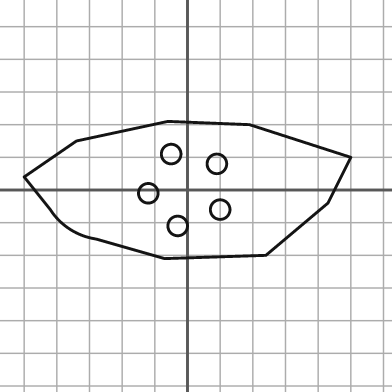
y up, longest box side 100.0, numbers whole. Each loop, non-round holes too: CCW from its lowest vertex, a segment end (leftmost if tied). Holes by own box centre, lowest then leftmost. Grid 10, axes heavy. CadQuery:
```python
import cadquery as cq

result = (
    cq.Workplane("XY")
    .moveTo(-7.0, -21.0)
    .lineTo(24.0, -20.0)
    .lineTo(43.0, -4.0)
    .lineTo(50.0, 10.0)
    .lineTo(19.0, 20.0)
    .lineTo(-6.0, 21.0)
    .lineTo(-34.0, 15.0)
    .lineTo(-50.0, 4.0)
    .lineTo(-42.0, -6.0)
    .threePointArc((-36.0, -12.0), (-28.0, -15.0))
    .close()
    .moveTo(-3.0, -11.0)
    .circle(3.0)
    .moveTo(10.0, -6.0)
    .circle(3.0)
    .moveTo(-12.0, -1.0)
    .circle(3.0)
    .moveTo(9.0, 8.0)
    .circle(3.0)
    .moveTo(-5.0, 11.0)
    .circle(3.0)
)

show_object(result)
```